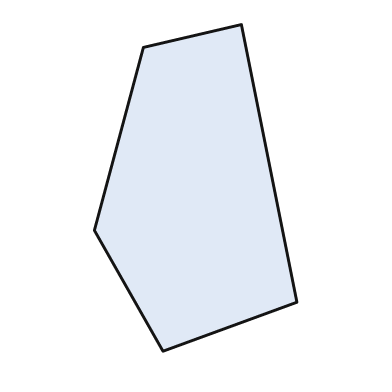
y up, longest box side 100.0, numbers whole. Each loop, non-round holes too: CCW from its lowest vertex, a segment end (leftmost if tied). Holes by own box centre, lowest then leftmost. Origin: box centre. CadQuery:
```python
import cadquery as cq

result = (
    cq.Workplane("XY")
    .moveTo(-10.0, -50.0)
    .lineTo(31.0, -35.0)
    .lineTo(14.0, 50.0)
    .lineTo(-16.0, 43.0)
    .lineTo(-31.0, -13.0)
    .close()
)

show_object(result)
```